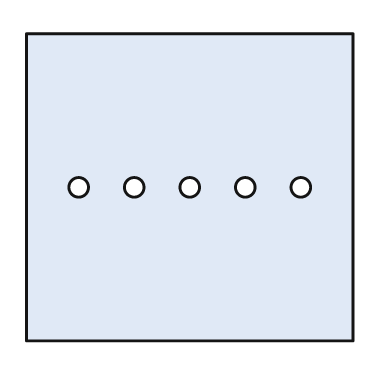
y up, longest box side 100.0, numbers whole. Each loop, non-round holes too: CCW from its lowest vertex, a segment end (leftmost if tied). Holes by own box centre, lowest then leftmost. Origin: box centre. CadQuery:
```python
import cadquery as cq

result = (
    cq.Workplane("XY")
    .moveTo(-50.0, -47.0)
    .lineTo(50.0, -47.0)
    .lineTo(50.0, 47.0)
    .lineTo(-50.0, 47.0)
    .close()
    .moveTo(-34.0, 0.0)
    .circle(3.0)
    .moveTo(-17.0, 0.0)
    .circle(3.0)
    .moveTo(0.0, 0.0)
    .circle(3.0)
    .moveTo(17.0, 0.0)
    .circle(3.0)
    .moveTo(34.0, 0.0)
    .circle(3.0)
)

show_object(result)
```